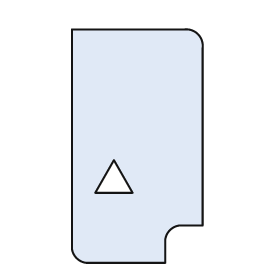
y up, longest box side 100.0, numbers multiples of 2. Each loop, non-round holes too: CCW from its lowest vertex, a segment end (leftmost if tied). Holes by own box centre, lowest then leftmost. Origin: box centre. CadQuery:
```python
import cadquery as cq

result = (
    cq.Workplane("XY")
    .moveTo(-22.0, -50.0)
    .lineTo(12.0, -50.0)
    .lineTo(12.0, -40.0)
    .threePointArc((14.0, -36.0), (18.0, -34.0))
    .lineTo(28.0, -34.0)
    .lineTo(28.0, 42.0)
    .threePointArc((26.0, 48.0), (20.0, 50.0))
    .lineTo(-28.0, 50.0)
    .lineTo(-28.0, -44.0)
    .threePointArc((-26.0, -48.0), (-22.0, -50.0))
    .close()
    .moveTo(-18.0, -20.0)
    .lineTo(-2.0, -20.0)
    .lineTo(-10.0, -6.0)
    .close()
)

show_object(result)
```